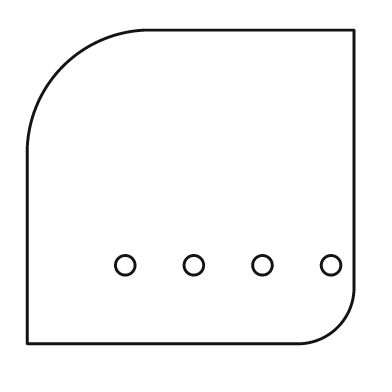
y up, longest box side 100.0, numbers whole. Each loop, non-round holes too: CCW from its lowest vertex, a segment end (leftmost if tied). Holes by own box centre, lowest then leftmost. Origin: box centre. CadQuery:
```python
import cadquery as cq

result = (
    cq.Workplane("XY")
    .moveTo(-50.0, -48.0)
    .lineTo(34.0, -48.0)
    .threePointArc((45.0, -43.0), (50.0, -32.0))
    .lineTo(50.0, 48.0)
    .lineTo(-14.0, 48.0)
    .threePointArc((-39.0, 37.0), (-50.0, 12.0))
    .close()
    .moveTo(-20.0, -24.0)
    .circle(3.0)
    .moveTo(1.0, -24.0)
    .circle(3.0)
    .moveTo(22.0, -24.0)
    .circle(3.0)
    .moveTo(43.0, -24.0)
    .circle(3.0)
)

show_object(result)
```